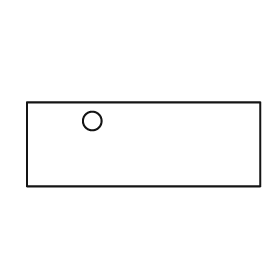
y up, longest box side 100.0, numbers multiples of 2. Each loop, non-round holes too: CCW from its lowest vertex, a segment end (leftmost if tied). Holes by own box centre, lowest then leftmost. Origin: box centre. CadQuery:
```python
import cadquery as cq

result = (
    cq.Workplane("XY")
    .moveTo(-50.0, -18.0)
    .lineTo(50.0, -18.0)
    .lineTo(50.0, 18.0)
    .lineTo(-50.0, 18.0)
    .close()
    .moveTo(-22.0, 10.0)
    .circle(4.0)
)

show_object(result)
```